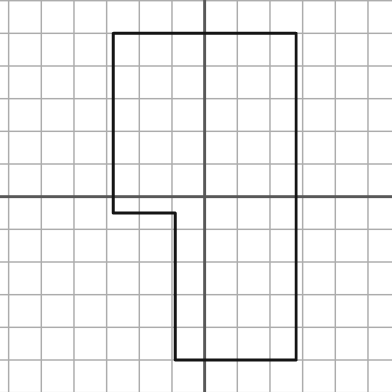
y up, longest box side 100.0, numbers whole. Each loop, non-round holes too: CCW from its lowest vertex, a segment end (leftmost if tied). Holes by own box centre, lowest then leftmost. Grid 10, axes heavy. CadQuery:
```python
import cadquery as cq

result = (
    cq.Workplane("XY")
    .moveTo(-9.0, -50.0)
    .lineTo(28.0, -50.0)
    .lineTo(28.0, 50.0)
    .lineTo(-28.0, 50.0)
    .lineTo(-28.0, -5.0)
    .lineTo(-9.0, -5.0)
    .close()
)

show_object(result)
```